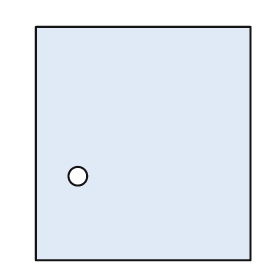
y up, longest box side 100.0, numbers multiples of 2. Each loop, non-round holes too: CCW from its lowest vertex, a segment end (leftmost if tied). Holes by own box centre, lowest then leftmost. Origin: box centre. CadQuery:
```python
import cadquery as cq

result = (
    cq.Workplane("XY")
    .moveTo(-46.0, -50.0)
    .lineTo(46.0, -50.0)
    .lineTo(46.0, 50.0)
    .lineTo(-46.0, 50.0)
    .close()
    .moveTo(-28.0, -14.0)
    .circle(4.0)
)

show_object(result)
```